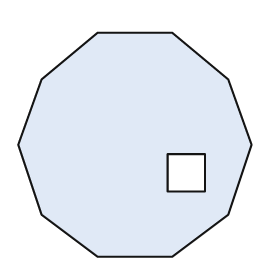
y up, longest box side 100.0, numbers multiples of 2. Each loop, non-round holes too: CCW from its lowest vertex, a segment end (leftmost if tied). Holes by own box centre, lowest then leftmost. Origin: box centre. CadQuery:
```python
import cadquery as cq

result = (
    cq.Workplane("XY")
    .moveTo(-16.0, -48.0)
    .lineTo(16.0, -48.0)
    .lineTo(40.0, -30.0)
    .lineTo(50.0, 0.0)
    .lineTo(40.0, 28.0)
    .lineTo(16.0, 48.0)
    .lineTo(-16.0, 48.0)
    .lineTo(-40.0, 28.0)
    .lineTo(-50.0, 0.0)
    .lineTo(-40.0, -30.0)
    .close()
    .moveTo(14.0, -20.0)
    .lineTo(30.0, -20.0)
    .lineTo(30.0, -4.0)
    .lineTo(14.0, -4.0)
    .close()
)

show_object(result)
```